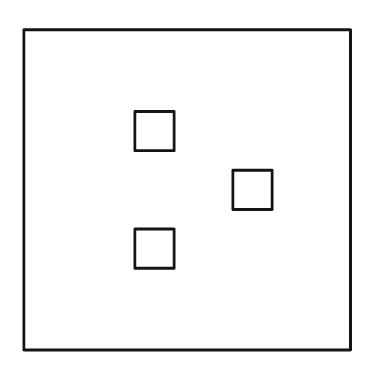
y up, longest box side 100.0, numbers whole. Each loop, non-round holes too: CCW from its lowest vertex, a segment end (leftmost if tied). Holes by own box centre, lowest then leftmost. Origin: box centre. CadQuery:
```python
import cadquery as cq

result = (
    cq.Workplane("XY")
    .moveTo(-50.0, -49.0)
    .lineTo(50.0, -49.0)
    .lineTo(50.0, 49.0)
    .lineTo(-50.0, 49.0)
    .close()
    .moveTo(-16.0, -24.0)
    .lineTo(-4.0, -24.0)
    .lineTo(-4.0, -12.0)
    .lineTo(-16.0, -12.0)
    .close()
    .moveTo(14.0, -6.0)
    .lineTo(26.0, -6.0)
    .lineTo(26.0, 6.0)
    .lineTo(14.0, 6.0)
    .close()
    .moveTo(-16.0, 12.0)
    .lineTo(-4.0, 12.0)
    .lineTo(-4.0, 24.0)
    .lineTo(-16.0, 24.0)
    .close()
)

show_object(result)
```